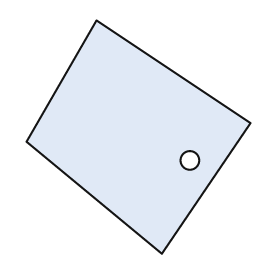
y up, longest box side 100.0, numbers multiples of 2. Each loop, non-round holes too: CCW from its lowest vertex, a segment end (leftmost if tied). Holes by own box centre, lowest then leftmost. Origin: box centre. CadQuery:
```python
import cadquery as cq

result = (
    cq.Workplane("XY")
    .moveTo(10.0, -50.0)
    .lineTo(48.0, 6.0)
    .lineTo(-18.0, 50.0)
    .lineTo(-48.0, -2.0)
    .close()
    .moveTo(22.0, -10.0)
    .circle(4.0)
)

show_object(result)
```